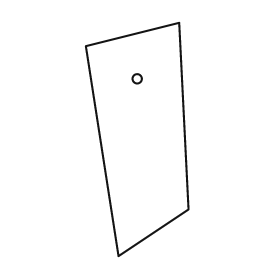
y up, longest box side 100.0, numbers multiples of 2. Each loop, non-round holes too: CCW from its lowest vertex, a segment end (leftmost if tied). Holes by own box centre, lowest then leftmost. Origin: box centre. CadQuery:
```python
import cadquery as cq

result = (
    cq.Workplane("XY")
    .moveTo(-8.0, -50.0)
    .lineTo(22.0, -30.0)
    .lineTo(18.0, 50.0)
    .lineTo(-22.0, 40.0)
    .close()
    .moveTo(0.0, 26.0)
    .circle(2.0)
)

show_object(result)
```